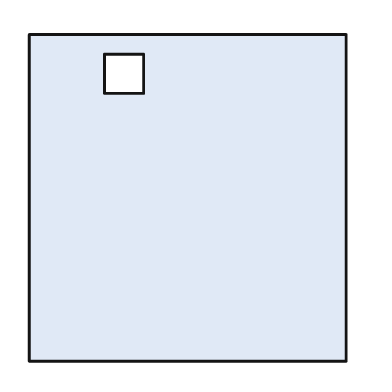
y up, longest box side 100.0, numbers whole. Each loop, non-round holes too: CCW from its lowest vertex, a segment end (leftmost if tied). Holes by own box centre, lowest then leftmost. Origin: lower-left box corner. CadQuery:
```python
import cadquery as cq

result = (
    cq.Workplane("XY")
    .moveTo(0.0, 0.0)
    .lineTo(97.0, 0.0)
    .lineTo(97.0, 100.0)
    .lineTo(0.0, 100.0)
    .close()
    .moveTo(23.0, 82.0)
    .lineTo(35.0, 82.0)
    .lineTo(35.0, 94.0)
    .lineTo(23.0, 94.0)
    .close()
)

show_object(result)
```